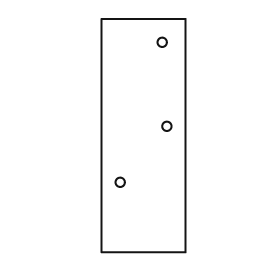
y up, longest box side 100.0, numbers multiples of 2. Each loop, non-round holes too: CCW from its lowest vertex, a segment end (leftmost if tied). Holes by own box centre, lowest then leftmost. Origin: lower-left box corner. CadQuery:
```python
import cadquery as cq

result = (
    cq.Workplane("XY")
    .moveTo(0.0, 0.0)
    .lineTo(36.0, 0.0)
    .lineTo(36.0, 100.0)
    .lineTo(0.0, 100.0)
    .close()
    .moveTo(8.0, 30.0)
    .circle(2.0)
    .moveTo(28.0, 54.0)
    .circle(2.0)
    .moveTo(26.0, 90.0)
    .circle(2.0)
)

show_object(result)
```